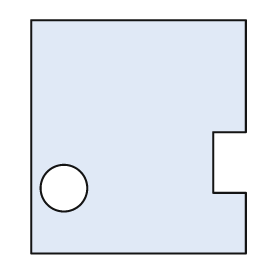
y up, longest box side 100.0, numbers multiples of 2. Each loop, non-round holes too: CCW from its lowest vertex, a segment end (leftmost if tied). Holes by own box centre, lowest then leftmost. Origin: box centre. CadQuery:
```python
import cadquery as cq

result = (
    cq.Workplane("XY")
    .moveTo(-46.0, -50.0)
    .lineTo(46.0, -50.0)
    .lineTo(46.0, -24.0)
    .lineTo(32.0, -24.0)
    .lineTo(32.0, 2.0)
    .lineTo(46.0, 2.0)
    .lineTo(46.0, 50.0)
    .lineTo(-46.0, 50.0)
    .close()
    .moveTo(-32.0, -22.0)
    .circle(10.0)
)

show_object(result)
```